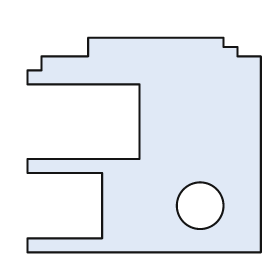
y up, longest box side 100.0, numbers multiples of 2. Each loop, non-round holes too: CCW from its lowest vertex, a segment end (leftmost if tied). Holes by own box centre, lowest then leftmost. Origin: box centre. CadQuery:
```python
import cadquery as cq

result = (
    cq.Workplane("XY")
    .moveTo(-50.0, -46.0)
    .lineTo(50.0, -46.0)
    .lineTo(50.0, 38.0)
    .lineTo(40.0, 38.0)
    .lineTo(40.0, 42.0)
    .lineTo(34.0, 42.0)
    .lineTo(34.0, 46.0)
    .lineTo(-24.0, 46.0)
    .lineTo(-24.0, 38.0)
    .lineTo(-44.0, 38.0)
    .lineTo(-44.0, 32.0)
    .lineTo(-50.0, 32.0)
    .lineTo(-50.0, 26.0)
    .lineTo(-2.0, 26.0)
    .lineTo(-2.0, -6.0)
    .lineTo(-50.0, -6.0)
    .lineTo(-50.0, -12.0)
    .lineTo(-18.0, -12.0)
    .lineTo(-18.0, -40.0)
    .lineTo(-50.0, -40.0)
    .close()
    .moveTo(24.0, -26.0)
    .circle(10.0)
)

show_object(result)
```